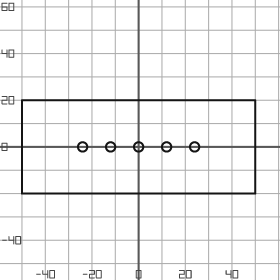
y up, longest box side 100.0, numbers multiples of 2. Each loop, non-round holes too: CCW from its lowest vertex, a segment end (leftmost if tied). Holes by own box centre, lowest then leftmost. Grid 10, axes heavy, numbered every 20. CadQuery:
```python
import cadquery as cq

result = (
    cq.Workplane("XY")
    .moveTo(-50.0, -20.0)
    .lineTo(50.0, -20.0)
    .lineTo(50.0, 20.0)
    .lineTo(-50.0, 20.0)
    .close()
    .moveTo(-24.0, 0.0)
    .circle(2.0)
    .moveTo(-12.0, 0.0)
    .circle(2.0)
    .moveTo(0.0, 0.0)
    .circle(2.0)
    .moveTo(12.0, 0.0)
    .circle(2.0)
    .moveTo(24.0, 0.0)
    .circle(2.0)
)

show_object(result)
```